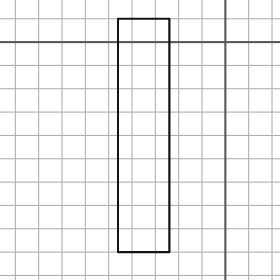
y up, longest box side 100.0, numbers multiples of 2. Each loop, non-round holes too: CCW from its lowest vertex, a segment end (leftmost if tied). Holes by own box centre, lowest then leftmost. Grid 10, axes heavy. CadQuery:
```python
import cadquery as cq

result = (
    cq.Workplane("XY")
    .moveTo(-46.0, -90.0)
    .lineTo(-24.0, -90.0)
    .lineTo(-24.0, 10.0)
    .lineTo(-46.0, 10.0)
    .close()
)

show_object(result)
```